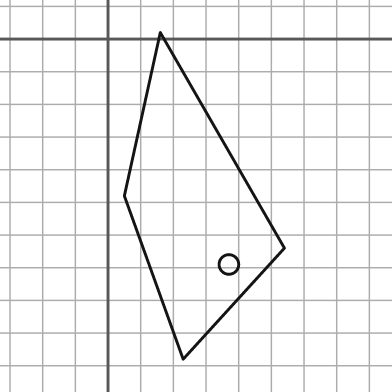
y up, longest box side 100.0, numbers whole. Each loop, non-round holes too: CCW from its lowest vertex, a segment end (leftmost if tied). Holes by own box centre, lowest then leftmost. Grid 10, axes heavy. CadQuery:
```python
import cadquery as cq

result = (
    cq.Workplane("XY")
    .moveTo(23.0, -98.0)
    .lineTo(54.0, -64.0)
    .lineTo(16.0, 2.0)
    .lineTo(5.0, -48.0)
    .close()
    .moveTo(37.0, -69.0)
    .circle(3.0)
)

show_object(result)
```